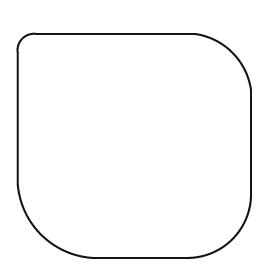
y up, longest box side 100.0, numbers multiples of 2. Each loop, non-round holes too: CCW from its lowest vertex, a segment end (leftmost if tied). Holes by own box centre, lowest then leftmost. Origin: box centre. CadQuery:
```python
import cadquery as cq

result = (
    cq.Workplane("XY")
    .moveTo(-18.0, -48.0)
    .lineTo(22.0, -48.0)
    .threePointArc((42.0, -40.0), (50.0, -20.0))
    .lineTo(50.0, 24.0)
    .threePointArc((42.0, 40.0), (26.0, 48.0))
    .lineTo(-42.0, 48.0)
    .threePointArc((-48.0, 46.0), (-50.0, 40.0))
    .lineTo(-50.0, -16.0)
    .threePointArc((-40.0, -38.0), (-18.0, -48.0))
    .close()
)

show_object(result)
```